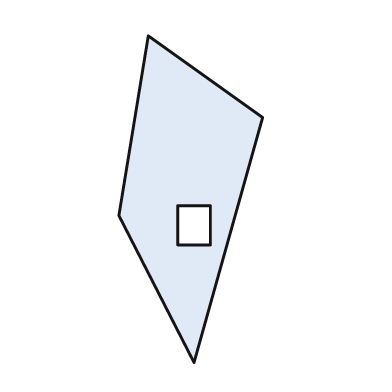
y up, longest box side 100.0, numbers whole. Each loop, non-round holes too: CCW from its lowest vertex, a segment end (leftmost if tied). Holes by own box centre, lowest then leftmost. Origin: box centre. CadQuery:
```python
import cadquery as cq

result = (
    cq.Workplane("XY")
    .moveTo(1.0, -50.0)
    .lineTo(22.0, 25.0)
    .lineTo(-13.0, 50.0)
    .lineTo(-22.0, -5.0)
    .close()
    .moveTo(-4.0, -14.0)
    .lineTo(6.0, -14.0)
    .lineTo(6.0, -2.0)
    .lineTo(-4.0, -2.0)
    .close()
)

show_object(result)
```